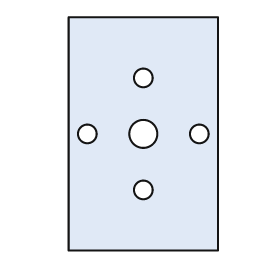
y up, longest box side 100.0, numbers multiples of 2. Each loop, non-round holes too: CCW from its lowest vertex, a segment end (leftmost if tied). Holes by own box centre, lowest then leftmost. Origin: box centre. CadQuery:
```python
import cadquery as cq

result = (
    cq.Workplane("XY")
    .moveTo(-32.0, -50.0)
    .lineTo(32.0, -50.0)
    .lineTo(32.0, 50.0)
    .lineTo(-32.0, 50.0)
    .close()
    .moveTo(0.0, -24.0)
    .circle(4.0)
    .moveTo(-24.0, 0.0)
    .circle(4.0)
    .moveTo(0.0, 0.0)
    .circle(6.0)
    .moveTo(24.0, 0.0)
    .circle(4.0)
    .moveTo(0.0, 24.0)
    .circle(4.0)
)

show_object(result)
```